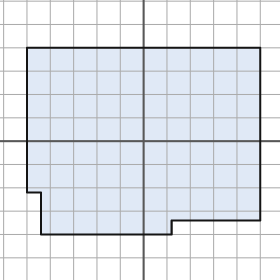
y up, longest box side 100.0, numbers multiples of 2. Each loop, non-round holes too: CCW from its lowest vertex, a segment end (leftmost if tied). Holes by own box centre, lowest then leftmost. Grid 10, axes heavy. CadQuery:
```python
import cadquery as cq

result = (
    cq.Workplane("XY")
    .moveTo(-44.0, -40.0)
    .lineTo(12.0, -40.0)
    .lineTo(12.0, -34.0)
    .lineTo(50.0, -34.0)
    .lineTo(50.0, 40.0)
    .lineTo(-50.0, 40.0)
    .lineTo(-50.0, -22.0)
    .lineTo(-44.0, -22.0)
    .close()
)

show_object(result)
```